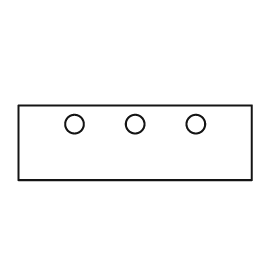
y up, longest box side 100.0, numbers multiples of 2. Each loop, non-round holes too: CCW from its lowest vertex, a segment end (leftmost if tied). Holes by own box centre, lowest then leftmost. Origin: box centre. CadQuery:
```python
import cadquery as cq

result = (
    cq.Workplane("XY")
    .moveTo(-50.0, -16.0)
    .lineTo(50.0, -16.0)
    .lineTo(50.0, 16.0)
    .lineTo(-50.0, 16.0)
    .close()
    .moveTo(-26.0, 8.0)
    .circle(4.0)
    .moveTo(0.0, 8.0)
    .circle(4.0)
    .moveTo(26.0, 8.0)
    .circle(4.0)
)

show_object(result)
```